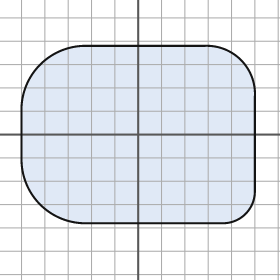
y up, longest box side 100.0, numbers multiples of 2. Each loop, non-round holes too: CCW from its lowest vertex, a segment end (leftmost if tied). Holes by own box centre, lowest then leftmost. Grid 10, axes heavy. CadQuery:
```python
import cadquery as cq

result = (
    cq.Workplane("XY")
    .moveTo(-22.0, -38.0)
    .lineTo(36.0, -38.0)
    .threePointArc((46.0, -34.0), (50.0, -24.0))
    .lineTo(50.0, 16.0)
    .threePointArc((44.0, 32.0), (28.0, 38.0))
    .lineTo(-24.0, 38.0)
    .threePointArc((-42.0, 30.0), (-50.0, 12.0))
    .lineTo(-50.0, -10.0)
    .threePointArc((-42.0, -30.0), (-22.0, -38.0))
    .close()
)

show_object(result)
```